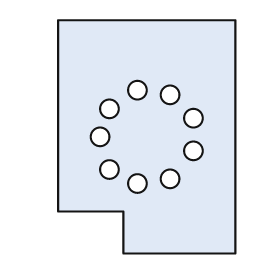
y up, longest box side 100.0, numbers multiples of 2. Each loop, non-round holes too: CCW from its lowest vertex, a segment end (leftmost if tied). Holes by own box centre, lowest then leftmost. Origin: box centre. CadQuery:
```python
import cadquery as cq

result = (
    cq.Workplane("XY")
    .moveTo(-10.0, -50.0)
    .lineTo(38.0, -50.0)
    .lineTo(38.0, 50.0)
    .lineTo(-38.0, 50.0)
    .lineTo(-38.0, -32.0)
    .lineTo(-10.0, -32.0)
    .close()
    .moveTo(-4.0, -20.0)
    .circle(4.0)
    .moveTo(10.0, -18.0)
    .circle(4.0)
    .moveTo(-16.0, -14.0)
    .circle(4.0)
    .moveTo(20.0, -6.0)
    .circle(4.0)
    .moveTo(-20.0, 0.0)
    .circle(4.0)
    .moveTo(20.0, 8.0)
    .circle(4.0)
    .moveTo(-16.0, 12.0)
    .circle(4.0)
    .moveTo(10.0, 18.0)
    .circle(4.0)
    .moveTo(-4.0, 20.0)
    .circle(4.0)
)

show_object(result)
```